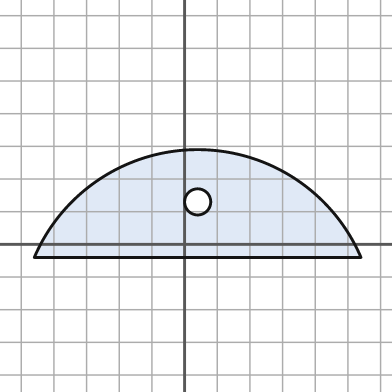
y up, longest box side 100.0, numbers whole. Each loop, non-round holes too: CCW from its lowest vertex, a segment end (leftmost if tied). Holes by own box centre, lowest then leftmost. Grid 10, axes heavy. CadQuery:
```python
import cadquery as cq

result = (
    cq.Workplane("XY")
    .moveTo(-46.0, -4.0)
    .lineTo(54.0, -4.0)
    .threePointArc((4.0, 29.0), (-46.0, -4.0))
    .close()
    .moveTo(4.0, 13.0)
    .circle(4.0)
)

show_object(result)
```